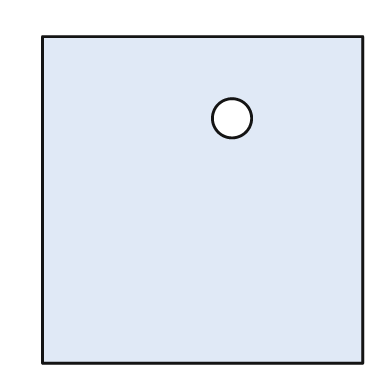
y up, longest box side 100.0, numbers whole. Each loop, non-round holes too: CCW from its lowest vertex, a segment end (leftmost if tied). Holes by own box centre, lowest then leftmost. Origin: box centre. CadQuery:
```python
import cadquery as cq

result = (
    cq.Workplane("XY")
    .moveTo(-49.0, -50.0)
    .lineTo(49.0, -50.0)
    .lineTo(49.0, 50.0)
    .lineTo(-49.0, 50.0)
    .close()
    .moveTo(9.0, 25.0)
    .circle(6.0)
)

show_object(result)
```